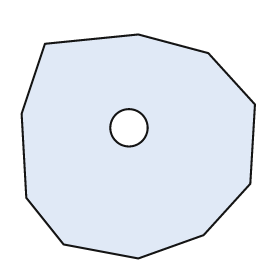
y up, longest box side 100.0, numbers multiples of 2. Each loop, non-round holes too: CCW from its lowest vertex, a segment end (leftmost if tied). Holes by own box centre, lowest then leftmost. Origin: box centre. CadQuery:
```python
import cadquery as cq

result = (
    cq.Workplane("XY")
    .moveTo(0.0, -48.0)
    .lineTo(28.0, -38.0)
    .lineTo(48.0, -16.0)
    .lineTo(50.0, 18.0)
    .lineTo(30.0, 40.0)
    .lineTo(0.0, 48.0)
    .lineTo(-40.0, 44.0)
    .lineTo(-50.0, 14.0)
    .lineTo(-48.0, -22.0)
    .lineTo(-32.0, -42.0)
    .close()
    .moveTo(-4.0, 8.0)
    .circle(8.0)
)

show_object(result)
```